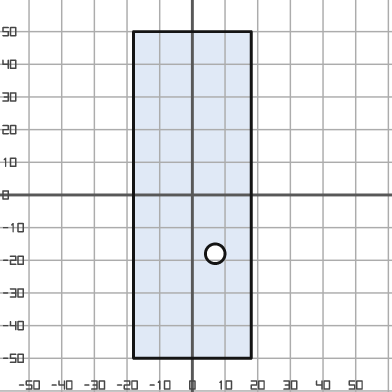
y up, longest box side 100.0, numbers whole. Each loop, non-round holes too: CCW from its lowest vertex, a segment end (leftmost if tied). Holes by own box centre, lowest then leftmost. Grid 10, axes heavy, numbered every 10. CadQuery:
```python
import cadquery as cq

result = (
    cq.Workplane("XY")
    .moveTo(-18.0, -50.0)
    .lineTo(18.0, -50.0)
    .lineTo(18.0, 50.0)
    .lineTo(-18.0, 50.0)
    .close()
    .moveTo(7.0, -18.0)
    .circle(3.0)
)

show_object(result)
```